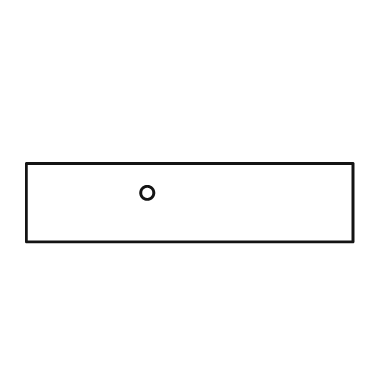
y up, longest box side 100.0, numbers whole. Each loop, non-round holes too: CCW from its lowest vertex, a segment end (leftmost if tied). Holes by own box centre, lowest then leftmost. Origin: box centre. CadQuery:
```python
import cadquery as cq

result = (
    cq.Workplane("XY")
    .moveTo(-50.0, -12.0)
    .lineTo(50.0, -12.0)
    .lineTo(50.0, 12.0)
    .lineTo(-50.0, 12.0)
    .close()
    .moveTo(-13.0, 3.0)
    .circle(2.0)
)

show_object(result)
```